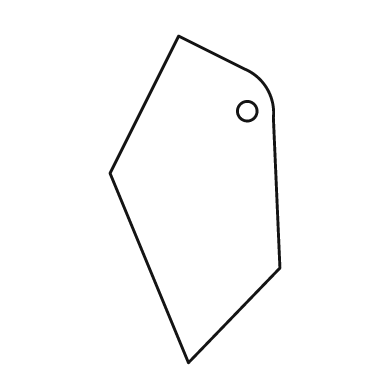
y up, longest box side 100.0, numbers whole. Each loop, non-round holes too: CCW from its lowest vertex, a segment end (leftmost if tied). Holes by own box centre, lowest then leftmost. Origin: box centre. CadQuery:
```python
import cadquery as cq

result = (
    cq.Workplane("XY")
    .moveTo(-2.0, -50.0)
    .lineTo(26.0, -21.0)
    .lineTo(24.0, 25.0)
    .threePointArc((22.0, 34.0), (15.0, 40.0))
    .lineTo(-5.0, 50.0)
    .lineTo(-26.0, 8.0)
    .close()
    .moveTo(16.0, 27.0)
    .circle(3.0)
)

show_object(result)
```